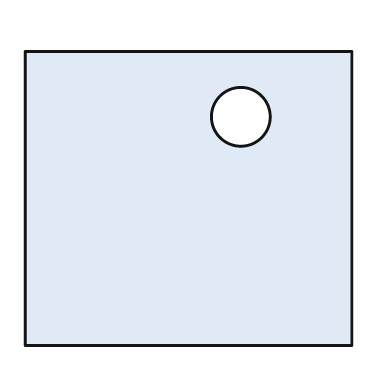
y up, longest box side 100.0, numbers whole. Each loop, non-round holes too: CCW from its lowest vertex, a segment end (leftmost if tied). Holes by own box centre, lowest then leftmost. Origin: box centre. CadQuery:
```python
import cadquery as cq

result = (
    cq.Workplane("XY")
    .moveTo(-50.0, -45.0)
    .lineTo(50.0, -45.0)
    .lineTo(50.0, 45.0)
    .lineTo(-50.0, 45.0)
    .close()
    .moveTo(16.0, 25.0)
    .circle(9.0)
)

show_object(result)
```